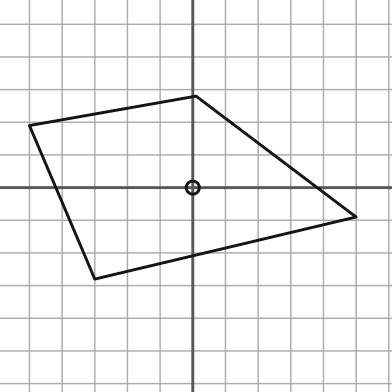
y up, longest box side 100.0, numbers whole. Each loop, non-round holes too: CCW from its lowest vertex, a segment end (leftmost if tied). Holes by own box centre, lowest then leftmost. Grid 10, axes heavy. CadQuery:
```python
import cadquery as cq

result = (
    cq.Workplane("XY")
    .moveTo(-30.0, -28.0)
    .lineTo(50.0, -9.0)
    .lineTo(1.0, 28.0)
    .lineTo(-50.0, 19.0)
    .close()
    .moveTo(0.0, 0.0)
    .circle(2.0)
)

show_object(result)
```